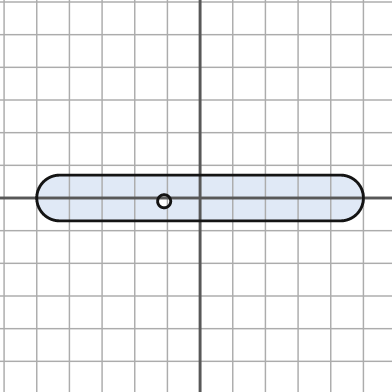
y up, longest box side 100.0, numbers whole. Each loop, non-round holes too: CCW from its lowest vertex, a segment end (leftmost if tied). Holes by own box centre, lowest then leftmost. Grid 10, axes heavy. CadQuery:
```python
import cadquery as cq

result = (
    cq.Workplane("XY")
    .moveTo(-43.0, -7.0)
    .lineTo(43.0, -7.0)
    .threePointArc((50.0, 0.0), (43.0, 7.0))
    .lineTo(-43.0, 7.0)
    .threePointArc((-50.0, 0.0), (-43.0, -7.0))
    .close()
    .moveTo(-11.0, -1.0)
    .circle(2.0)
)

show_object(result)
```